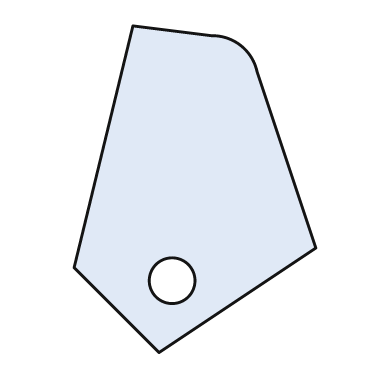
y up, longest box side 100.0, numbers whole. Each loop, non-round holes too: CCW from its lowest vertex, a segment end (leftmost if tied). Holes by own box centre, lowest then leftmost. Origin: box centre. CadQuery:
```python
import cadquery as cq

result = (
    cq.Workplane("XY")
    .moveTo(-11.0, -50.0)
    .lineTo(37.0, -18.0)
    .lineTo(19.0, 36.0)
    .threePointArc((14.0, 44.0), (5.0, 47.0))
    .lineTo(-19.0, 50.0)
    .lineTo(-37.0, -24.0)
    .close()
    .moveTo(-7.0, -28.0)
    .circle(7.0)
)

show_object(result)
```